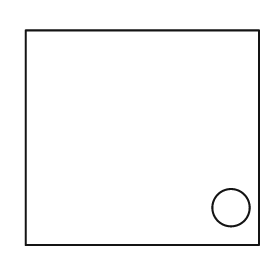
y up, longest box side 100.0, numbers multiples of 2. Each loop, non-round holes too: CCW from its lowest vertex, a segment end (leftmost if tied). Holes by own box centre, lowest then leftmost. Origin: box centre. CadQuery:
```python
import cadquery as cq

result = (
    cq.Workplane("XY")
    .moveTo(-50.0, -46.0)
    .lineTo(50.0, -46.0)
    .lineTo(50.0, 46.0)
    .lineTo(-50.0, 46.0)
    .close()
    .moveTo(38.0, -30.0)
    .circle(8.0)
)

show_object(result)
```